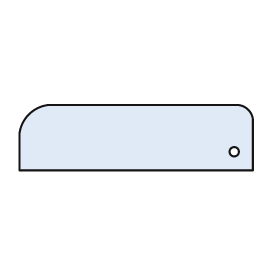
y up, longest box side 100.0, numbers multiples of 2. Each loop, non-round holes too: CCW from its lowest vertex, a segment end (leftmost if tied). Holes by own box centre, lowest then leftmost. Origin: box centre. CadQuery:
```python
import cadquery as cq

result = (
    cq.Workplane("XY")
    .moveTo(-50.0, -14.0)
    .lineTo(50.0, -14.0)
    .lineTo(50.0, 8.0)
    .threePointArc((48.0, 12.0), (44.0, 14.0))
    .lineTo(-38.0, 14.0)
    .threePointArc((-46.0, 10.0), (-50.0, 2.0))
    .close()
    .moveTo(42.0, -6.0)
    .circle(2.0)
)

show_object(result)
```